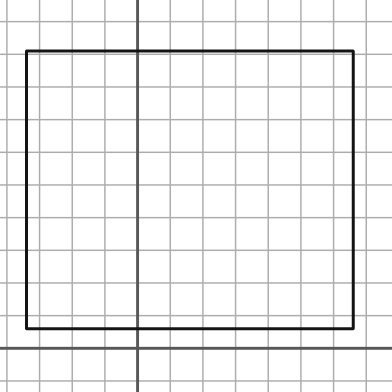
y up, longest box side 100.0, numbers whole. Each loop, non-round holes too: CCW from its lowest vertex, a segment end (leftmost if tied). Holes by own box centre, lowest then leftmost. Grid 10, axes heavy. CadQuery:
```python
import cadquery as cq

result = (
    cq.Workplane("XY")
    .moveTo(-34.0, 6.0)
    .lineTo(66.0, 6.0)
    .lineTo(66.0, 91.0)
    .lineTo(-34.0, 91.0)
    .close()
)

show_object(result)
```